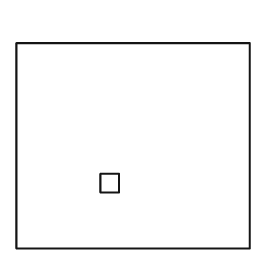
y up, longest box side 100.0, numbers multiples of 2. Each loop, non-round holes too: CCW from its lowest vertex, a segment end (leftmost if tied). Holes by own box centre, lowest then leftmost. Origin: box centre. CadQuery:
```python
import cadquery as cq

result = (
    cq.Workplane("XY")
    .moveTo(-50.0, -44.0)
    .lineTo(50.0, -44.0)
    .lineTo(50.0, 44.0)
    .lineTo(-50.0, 44.0)
    .close()
    .moveTo(-14.0, -20.0)
    .lineTo(-6.0, -20.0)
    .lineTo(-6.0, -12.0)
    .lineTo(-14.0, -12.0)
    .close()
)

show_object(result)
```